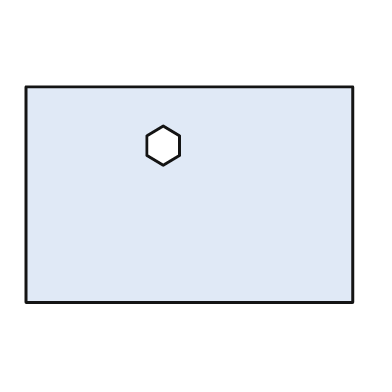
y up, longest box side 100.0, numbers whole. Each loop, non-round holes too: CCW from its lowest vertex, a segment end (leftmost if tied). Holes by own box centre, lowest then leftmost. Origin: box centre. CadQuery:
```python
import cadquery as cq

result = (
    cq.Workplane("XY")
    .moveTo(-50.0, -33.0)
    .lineTo(50.0, -33.0)
    .lineTo(50.0, 33.0)
    .lineTo(-50.0, 33.0)
    .close()
    .moveTo(-8.0, 9.0)
    .lineTo(-3.0, 12.0)
    .lineTo(-3.0, 18.0)
    .lineTo(-8.0, 21.0)
    .lineTo(-13.0, 18.0)
    .lineTo(-13.0, 12.0)
    .close()
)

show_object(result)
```